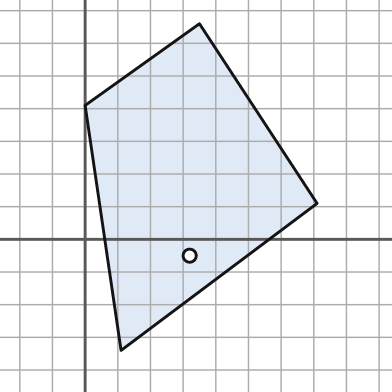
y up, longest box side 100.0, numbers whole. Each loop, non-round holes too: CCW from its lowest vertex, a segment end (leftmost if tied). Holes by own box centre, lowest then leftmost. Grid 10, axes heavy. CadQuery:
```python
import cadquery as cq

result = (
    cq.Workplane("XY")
    .moveTo(11.0, -34.0)
    .lineTo(71.0, 11.0)
    .lineTo(35.0, 66.0)
    .lineTo(0.0, 41.0)
    .close()
    .moveTo(32.0, -5.0)
    .circle(2.0)
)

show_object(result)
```